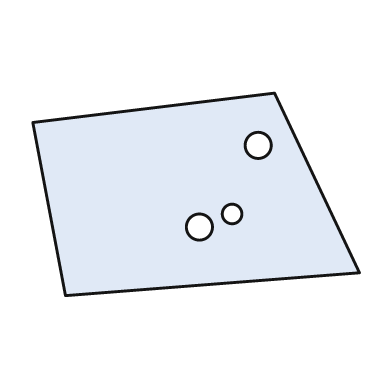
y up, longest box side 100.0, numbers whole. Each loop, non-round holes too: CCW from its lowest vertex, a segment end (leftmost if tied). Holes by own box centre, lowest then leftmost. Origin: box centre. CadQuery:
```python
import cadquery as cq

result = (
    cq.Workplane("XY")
    .moveTo(-40.0, -31.0)
    .lineTo(50.0, -24.0)
    .lineTo(24.0, 31.0)
    .lineTo(-50.0, 22.0)
    .close()
    .moveTo(1.0, -10.0)
    .circle(4.0)
    .moveTo(11.0, -6.0)
    .circle(3.0)
    .moveTo(19.0, 15.0)
    .circle(4.0)
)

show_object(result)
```